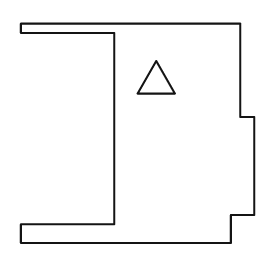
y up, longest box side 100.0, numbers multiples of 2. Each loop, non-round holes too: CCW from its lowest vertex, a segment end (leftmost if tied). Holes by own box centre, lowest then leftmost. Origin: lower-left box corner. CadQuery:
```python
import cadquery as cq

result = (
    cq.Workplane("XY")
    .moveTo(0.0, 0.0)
    .lineTo(90.0, 0.0)
    .lineTo(90.0, 12.0)
    .lineTo(100.0, 12.0)
    .lineTo(100.0, 54.0)
    .lineTo(94.0, 54.0)
    .lineTo(94.0, 94.0)
    .lineTo(0.0, 94.0)
    .lineTo(0.0, 90.0)
    .lineTo(40.0, 90.0)
    .lineTo(40.0, 8.0)
    .lineTo(0.0, 8.0)
    .close()
    .moveTo(50.0, 64.0)
    .lineTo(66.0, 64.0)
    .lineTo(58.0, 78.0)
    .close()
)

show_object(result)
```